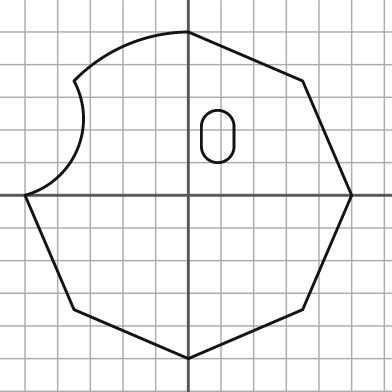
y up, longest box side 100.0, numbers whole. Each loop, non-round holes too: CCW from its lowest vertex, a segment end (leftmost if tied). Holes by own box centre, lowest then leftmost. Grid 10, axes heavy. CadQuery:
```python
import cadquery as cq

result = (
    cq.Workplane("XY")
    .moveTo(0.0, -50.0)
    .lineTo(35.0, -35.0)
    .lineTo(50.0, 0.0)
    .lineTo(35.0, 35.0)
    .lineTo(0.0, 50.0)
    .threePointArc((-19.0, 46.0), (-35.0, 35.0))
    .threePointArc((-34.0, 14.0), (-50.0, 0.0))
    .lineTo(-35.0, -35.0)
    .close()
    .moveTo(4.0, 15.0)
    .threePointArc((9.0, 10.0), (14.0, 15.0))
    .lineTo(14.0, 21.0)
    .threePointArc((9.0, 26.0), (4.0, 21.0))
    .close()
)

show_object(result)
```